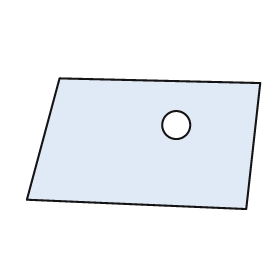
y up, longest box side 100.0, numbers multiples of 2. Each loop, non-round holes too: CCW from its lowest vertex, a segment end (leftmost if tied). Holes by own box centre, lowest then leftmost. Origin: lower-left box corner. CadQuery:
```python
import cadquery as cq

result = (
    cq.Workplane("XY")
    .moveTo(94.0, 0.0)
    .lineTo(100.0, 54.0)
    .lineTo(14.0, 56.0)
    .lineTo(0.0, 4.0)
    .close()
    .moveTo(64.0, 36.0)
    .circle(6.0)
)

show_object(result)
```